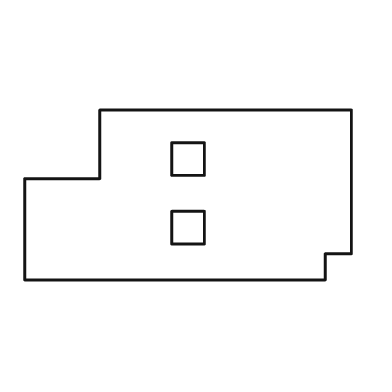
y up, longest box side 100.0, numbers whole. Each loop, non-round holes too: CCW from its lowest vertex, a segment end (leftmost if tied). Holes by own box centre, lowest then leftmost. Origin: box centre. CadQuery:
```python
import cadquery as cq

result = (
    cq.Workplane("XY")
    .moveTo(-50.0, -26.0)
    .lineTo(42.0, -26.0)
    .lineTo(42.0, -18.0)
    .lineTo(50.0, -18.0)
    .lineTo(50.0, 26.0)
    .lineTo(-27.0, 26.0)
    .lineTo(-27.0, 5.0)
    .lineTo(-50.0, 5.0)
    .close()
    .moveTo(-5.0, -15.0)
    .lineTo(5.0, -15.0)
    .lineTo(5.0, -5.0)
    .lineTo(-5.0, -5.0)
    .close()
    .moveTo(-5.0, 6.0)
    .lineTo(5.0, 6.0)
    .lineTo(5.0, 16.0)
    .lineTo(-5.0, 16.0)
    .close()
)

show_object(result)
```